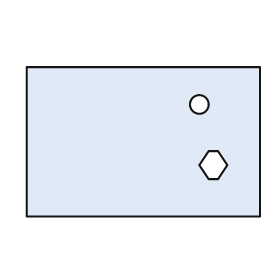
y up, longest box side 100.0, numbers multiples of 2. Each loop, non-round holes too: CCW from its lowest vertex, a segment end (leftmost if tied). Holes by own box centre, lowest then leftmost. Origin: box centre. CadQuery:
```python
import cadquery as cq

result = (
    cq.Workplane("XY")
    .moveTo(-50.0, -32.0)
    .lineTo(50.0, -32.0)
    .lineTo(50.0, 32.0)
    .lineTo(-50.0, 32.0)
    .close()
    .moveTo(28.0, -16.0)
    .lineTo(32.0, -16.0)
    .lineTo(36.0, -10.0)
    .lineTo(32.0, -4.0)
    .lineTo(28.0, -4.0)
    .lineTo(24.0, -10.0)
    .close()
    .moveTo(24.0, 16.0)
    .circle(4.0)
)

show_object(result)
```